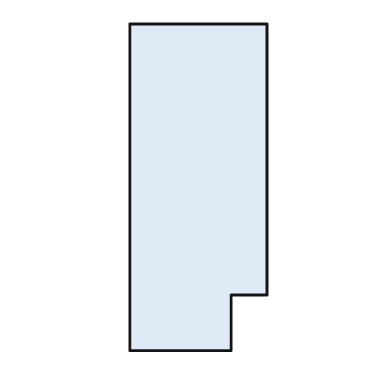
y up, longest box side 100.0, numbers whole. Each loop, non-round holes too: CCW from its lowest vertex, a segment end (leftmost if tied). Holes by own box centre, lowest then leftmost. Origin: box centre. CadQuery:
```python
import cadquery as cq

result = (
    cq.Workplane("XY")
    .moveTo(-21.0, -50.0)
    .lineTo(10.0, -50.0)
    .lineTo(10.0, -33.0)
    .lineTo(21.0, -33.0)
    .lineTo(21.0, 50.0)
    .lineTo(-21.0, 50.0)
    .close()
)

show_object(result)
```